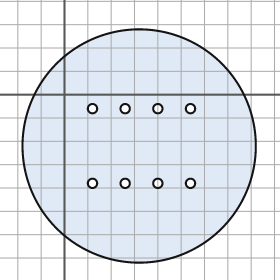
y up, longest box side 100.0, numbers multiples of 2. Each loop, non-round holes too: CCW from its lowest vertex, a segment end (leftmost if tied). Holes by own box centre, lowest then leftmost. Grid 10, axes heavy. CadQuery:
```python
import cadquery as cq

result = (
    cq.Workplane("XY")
    .moveTo(32.0, -22.0)
    .circle(50.0)
    .moveTo(12.0, -38.0)
    .circle(2.0)
    .moveTo(26.0, -38.0)
    .circle(2.0)
    .moveTo(40.0, -38.0)
    .circle(2.0)
    .moveTo(54.0, -38.0)
    .circle(2.0)
    .moveTo(12.0, -6.0)
    .circle(2.0)
    .moveTo(26.0, -6.0)
    .circle(2.0)
    .moveTo(40.0, -6.0)
    .circle(2.0)
    .moveTo(54.0, -6.0)
    .circle(2.0)
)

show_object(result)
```